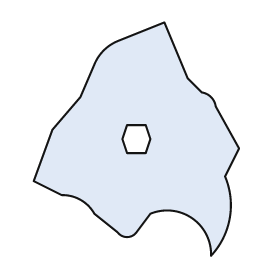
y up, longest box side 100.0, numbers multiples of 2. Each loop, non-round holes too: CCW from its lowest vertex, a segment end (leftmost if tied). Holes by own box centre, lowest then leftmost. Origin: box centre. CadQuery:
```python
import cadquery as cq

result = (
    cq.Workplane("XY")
    .moveTo(32.0, -50.0)
    .threePointArc((40.0, -34.0), (38.0, -16.0))
    .lineTo(44.0, -4.0)
    .lineTo(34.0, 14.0)
    .threePointArc((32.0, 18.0), (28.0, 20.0))
    .lineTo(22.0, 26.0)
    .lineTo(12.0, 50.0)
    .lineTo(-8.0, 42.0)
    .threePointArc((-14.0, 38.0), (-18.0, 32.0))
    .lineTo(-24.0, 18.0)
    .lineTo(-36.0, 4.0)
    .lineTo(-44.0, -18.0)
    .lineTo(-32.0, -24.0)
    .threePointArc((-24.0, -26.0), (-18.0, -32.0))
    .lineTo(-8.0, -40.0)
    .threePointArc((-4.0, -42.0), (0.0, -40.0))
    .lineTo(6.0, -32.0)
    .threePointArc((24.0, -34.0), (32.0, -50.0))
    .close()
    .moveTo(-4.0, -6.0)
    .lineTo(4.0, -6.0)
    .lineTo(6.0, 0.0)
    .lineTo(4.0, 6.0)
    .lineTo(-4.0, 6.0)
    .lineTo(-6.0, 0.0)
    .close()
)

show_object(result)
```